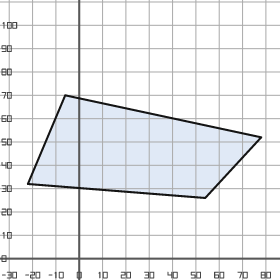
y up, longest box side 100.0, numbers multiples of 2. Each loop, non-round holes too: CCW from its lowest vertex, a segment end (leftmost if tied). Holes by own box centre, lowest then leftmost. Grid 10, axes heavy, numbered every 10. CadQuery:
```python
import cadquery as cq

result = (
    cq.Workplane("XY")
    .moveTo(54.0, 26.0)
    .lineTo(78.0, 52.0)
    .lineTo(-6.0, 70.0)
    .lineTo(-22.0, 32.0)
    .close()
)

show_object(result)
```